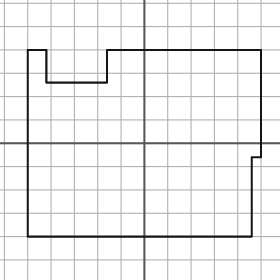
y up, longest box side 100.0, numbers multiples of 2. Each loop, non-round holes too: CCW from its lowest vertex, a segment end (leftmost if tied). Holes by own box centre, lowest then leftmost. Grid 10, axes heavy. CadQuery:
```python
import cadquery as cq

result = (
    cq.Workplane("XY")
    .moveTo(-50.0, -40.0)
    .lineTo(46.0, -40.0)
    .lineTo(46.0, -6.0)
    .lineTo(50.0, -6.0)
    .lineTo(50.0, 40.0)
    .lineTo(-16.0, 40.0)
    .lineTo(-16.0, 26.0)
    .lineTo(-42.0, 26.0)
    .lineTo(-42.0, 40.0)
    .lineTo(-50.0, 40.0)
    .close()
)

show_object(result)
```